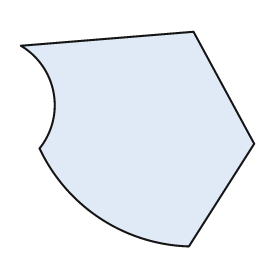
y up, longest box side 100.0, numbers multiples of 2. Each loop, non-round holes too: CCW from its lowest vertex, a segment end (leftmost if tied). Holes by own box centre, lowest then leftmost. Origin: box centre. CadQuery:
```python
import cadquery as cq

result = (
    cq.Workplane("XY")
    .moveTo(22.0, -46.0)
    .lineTo(50.0, -2.0)
    .lineTo(24.0, 46.0)
    .lineTo(-50.0, 40.0)
    .threePointArc((-36.0, 20.0), (-42.0, -4.0))
    .threePointArc((-16.0, -34.0), (22.0, -46.0))
    .close()
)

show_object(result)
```